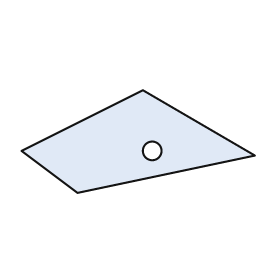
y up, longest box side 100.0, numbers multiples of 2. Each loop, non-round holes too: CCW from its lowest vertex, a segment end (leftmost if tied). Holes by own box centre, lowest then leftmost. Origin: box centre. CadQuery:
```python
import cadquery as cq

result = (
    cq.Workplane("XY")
    .moveTo(-26.0, -22.0)
    .lineTo(50.0, -6.0)
    .lineTo(2.0, 22.0)
    .lineTo(-50.0, -4.0)
    .close()
    .moveTo(6.0, -4.0)
    .circle(4.0)
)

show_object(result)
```